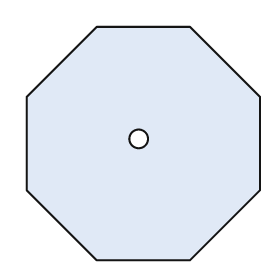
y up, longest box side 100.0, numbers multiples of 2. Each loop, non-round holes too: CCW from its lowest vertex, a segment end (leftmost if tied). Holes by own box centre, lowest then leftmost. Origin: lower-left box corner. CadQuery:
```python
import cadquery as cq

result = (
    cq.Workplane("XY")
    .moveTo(30.0, 0.0)
    .lineTo(70.0, 0.0)
    .lineTo(100.0, 30.0)
    .lineTo(100.0, 70.0)
    .lineTo(70.0, 100.0)
    .lineTo(30.0, 100.0)
    .lineTo(0.0, 70.0)
    .lineTo(0.0, 30.0)
    .close()
    .moveTo(48.0, 52.0)
    .circle(4.0)
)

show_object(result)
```